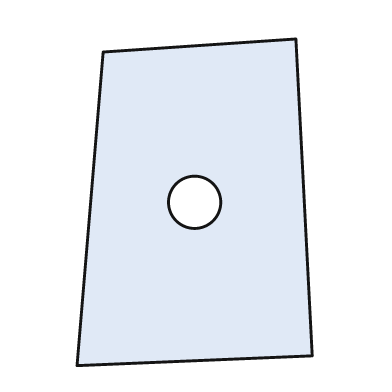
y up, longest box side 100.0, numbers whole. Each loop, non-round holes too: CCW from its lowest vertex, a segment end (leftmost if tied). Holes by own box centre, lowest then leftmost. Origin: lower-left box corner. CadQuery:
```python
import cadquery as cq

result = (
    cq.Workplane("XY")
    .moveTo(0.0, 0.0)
    .lineTo(72.0, 3.0)
    .lineTo(67.0, 100.0)
    .lineTo(8.0, 96.0)
    .close()
    .moveTo(36.0, 50.0)
    .circle(8.0)
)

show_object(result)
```